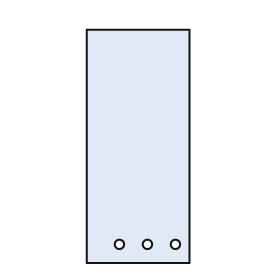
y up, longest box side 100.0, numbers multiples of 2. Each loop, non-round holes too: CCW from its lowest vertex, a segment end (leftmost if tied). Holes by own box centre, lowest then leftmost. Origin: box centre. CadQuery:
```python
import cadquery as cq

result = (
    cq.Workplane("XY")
    .moveTo(-22.0, -50.0)
    .lineTo(22.0, -50.0)
    .lineTo(22.0, 50.0)
    .lineTo(-22.0, 50.0)
    .close()
    .moveTo(-8.0, -42.0)
    .circle(2.0)
    .moveTo(4.0, -42.0)
    .circle(2.0)
    .moveTo(16.0, -42.0)
    .circle(2.0)
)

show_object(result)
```